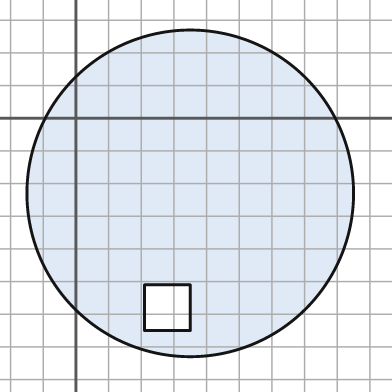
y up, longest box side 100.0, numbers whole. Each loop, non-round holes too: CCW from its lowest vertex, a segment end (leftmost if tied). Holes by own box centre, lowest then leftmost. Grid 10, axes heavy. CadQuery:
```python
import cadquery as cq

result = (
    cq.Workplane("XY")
    .moveTo(35.0, -23.0)
    .circle(50.0)
    .moveTo(21.0, -65.0)
    .lineTo(35.0, -65.0)
    .lineTo(35.0, -51.0)
    .lineTo(21.0, -51.0)
    .close()
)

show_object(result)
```